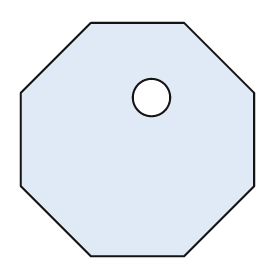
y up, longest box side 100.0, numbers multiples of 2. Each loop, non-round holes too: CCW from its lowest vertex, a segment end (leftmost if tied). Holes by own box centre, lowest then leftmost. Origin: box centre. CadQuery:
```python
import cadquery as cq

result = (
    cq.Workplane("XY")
    .moveTo(-20.0, -50.0)
    .lineTo(20.0, -50.0)
    .lineTo(50.0, -20.0)
    .lineTo(50.0, 20.0)
    .lineTo(20.0, 50.0)
    .lineTo(-20.0, 50.0)
    .lineTo(-50.0, 20.0)
    .lineTo(-50.0, -20.0)
    .close()
    .moveTo(6.0, 18.0)
    .circle(8.0)
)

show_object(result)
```